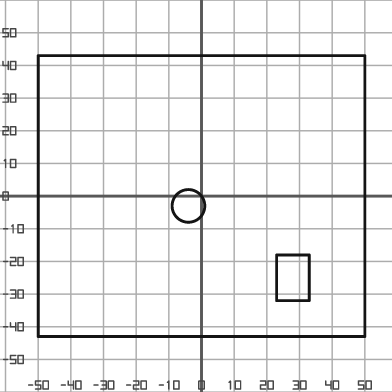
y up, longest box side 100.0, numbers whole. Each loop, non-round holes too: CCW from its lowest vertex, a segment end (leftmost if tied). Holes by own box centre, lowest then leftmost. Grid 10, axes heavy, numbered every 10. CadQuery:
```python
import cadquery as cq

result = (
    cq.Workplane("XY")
    .moveTo(-50.0, -43.0)
    .lineTo(50.0, -43.0)
    .lineTo(50.0, 43.0)
    .lineTo(-50.0, 43.0)
    .close()
    .moveTo(23.0, -32.0)
    .lineTo(33.0, -32.0)
    .lineTo(33.0, -18.0)
    .lineTo(23.0, -18.0)
    .close()
    .moveTo(-4.0, -3.0)
    .circle(5.0)
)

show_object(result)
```